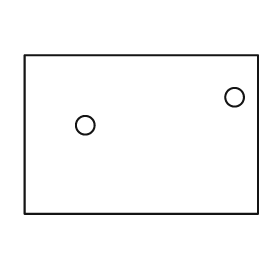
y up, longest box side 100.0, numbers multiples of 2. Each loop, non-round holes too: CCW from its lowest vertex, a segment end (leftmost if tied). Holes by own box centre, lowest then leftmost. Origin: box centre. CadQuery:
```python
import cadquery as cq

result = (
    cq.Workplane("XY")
    .moveTo(-50.0, -34.0)
    .lineTo(50.0, -34.0)
    .lineTo(50.0, 34.0)
    .lineTo(-50.0, 34.0)
    .close()
    .moveTo(-24.0, 4.0)
    .circle(4.0)
    .moveTo(40.0, 16.0)
    .circle(4.0)
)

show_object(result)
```